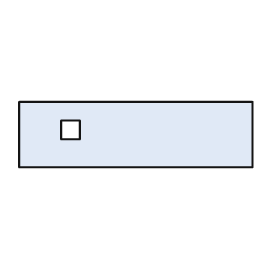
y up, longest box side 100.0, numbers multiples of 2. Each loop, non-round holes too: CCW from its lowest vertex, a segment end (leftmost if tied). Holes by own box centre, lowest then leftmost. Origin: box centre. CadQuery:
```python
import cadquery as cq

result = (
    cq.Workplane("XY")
    .moveTo(-50.0, -14.0)
    .lineTo(50.0, -14.0)
    .lineTo(50.0, 14.0)
    .lineTo(-50.0, 14.0)
    .close()
    .moveTo(-32.0, -2.0)
    .lineTo(-24.0, -2.0)
    .lineTo(-24.0, 6.0)
    .lineTo(-32.0, 6.0)
    .close()
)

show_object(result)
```